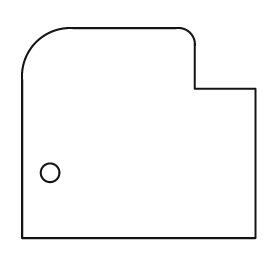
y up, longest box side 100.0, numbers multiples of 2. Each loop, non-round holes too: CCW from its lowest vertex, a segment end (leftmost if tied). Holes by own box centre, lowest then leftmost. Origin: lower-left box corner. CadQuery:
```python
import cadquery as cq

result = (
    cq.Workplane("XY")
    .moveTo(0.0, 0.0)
    .lineTo(100.0, 0.0)
    .lineTo(100.0, 64.0)
    .lineTo(74.0, 64.0)
    .lineTo(74.0, 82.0)
    .threePointArc((72.0, 88.0), (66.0, 90.0))
    .lineTo(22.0, 90.0)
    .threePointArc((6.0, 84.0), (0.0, 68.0))
    .close()
    .moveTo(12.0, 28.0)
    .circle(4.0)
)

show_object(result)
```